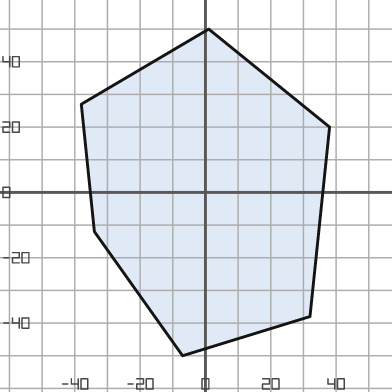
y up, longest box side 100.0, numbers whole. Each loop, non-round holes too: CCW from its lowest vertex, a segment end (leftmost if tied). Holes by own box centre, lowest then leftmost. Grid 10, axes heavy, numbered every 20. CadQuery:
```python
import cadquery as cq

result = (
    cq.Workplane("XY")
    .moveTo(-7.0, -50.0)
    .lineTo(32.0, -38.0)
    .lineTo(38.0, 20.0)
    .lineTo(1.0, 50.0)
    .lineTo(-38.0, 27.0)
    .lineTo(-34.0, -12.0)
    .close()
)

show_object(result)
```